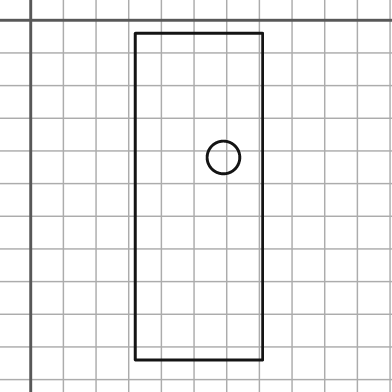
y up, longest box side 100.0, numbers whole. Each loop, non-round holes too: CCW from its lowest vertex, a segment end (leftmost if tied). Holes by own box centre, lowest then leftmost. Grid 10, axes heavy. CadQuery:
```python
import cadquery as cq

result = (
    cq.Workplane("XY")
    .moveTo(32.0, -104.0)
    .lineTo(71.0, -104.0)
    .lineTo(71.0, -4.0)
    .lineTo(32.0, -4.0)
    .close()
    .moveTo(59.0, -42.0)
    .circle(5.0)
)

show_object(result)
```